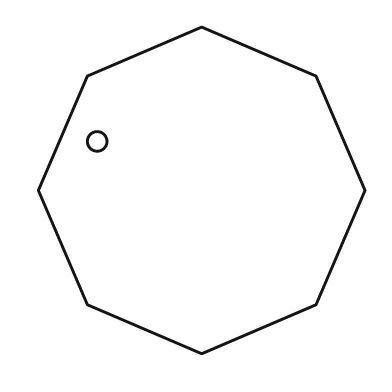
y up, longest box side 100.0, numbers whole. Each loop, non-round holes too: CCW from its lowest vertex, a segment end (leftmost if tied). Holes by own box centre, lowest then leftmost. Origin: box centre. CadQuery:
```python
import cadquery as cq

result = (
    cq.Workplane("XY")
    .moveTo(0.0, -50.0)
    .lineTo(35.0, -35.0)
    .lineTo(50.0, 0.0)
    .lineTo(35.0, 35.0)
    .lineTo(0.0, 50.0)
    .lineTo(-35.0, 35.0)
    .lineTo(-50.0, 0.0)
    .lineTo(-35.0, -35.0)
    .close()
    .moveTo(-32.0, 15.0)
    .circle(3.0)
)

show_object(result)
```